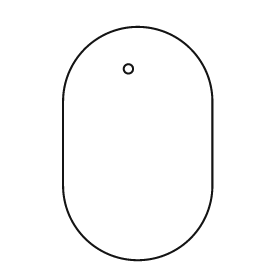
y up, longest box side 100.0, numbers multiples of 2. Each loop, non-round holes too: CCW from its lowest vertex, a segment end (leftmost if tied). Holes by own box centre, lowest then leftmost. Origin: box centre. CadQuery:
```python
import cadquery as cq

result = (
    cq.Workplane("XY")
    .moveTo(-32.0, -18.0)
    .threePointArc((0.0, -50.0), (32.0, -18.0))
    .lineTo(32.0, 18.0)
    .threePointArc((0.0, 50.0), (-32.0, 18.0))
    .close()
    .moveTo(-4.0, 32.0)
    .circle(2.0)
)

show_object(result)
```